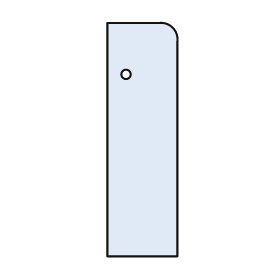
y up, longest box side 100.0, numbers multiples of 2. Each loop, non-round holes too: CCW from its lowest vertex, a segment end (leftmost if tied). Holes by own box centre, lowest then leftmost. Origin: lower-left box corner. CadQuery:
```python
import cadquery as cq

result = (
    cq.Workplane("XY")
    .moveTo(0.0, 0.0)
    .lineTo(30.0, 0.0)
    .lineTo(30.0, 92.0)
    .threePointArc((28.0, 98.0), (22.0, 100.0))
    .lineTo(0.0, 100.0)
    .close()
    .moveTo(8.0, 78.0)
    .circle(2.0)
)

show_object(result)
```